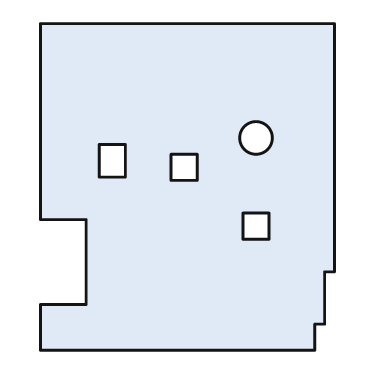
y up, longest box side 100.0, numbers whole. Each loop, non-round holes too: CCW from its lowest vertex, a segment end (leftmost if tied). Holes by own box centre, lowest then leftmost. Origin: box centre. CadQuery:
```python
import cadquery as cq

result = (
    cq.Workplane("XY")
    .moveTo(-45.0, -50.0)
    .lineTo(39.0, -50.0)
    .lineTo(39.0, -42.0)
    .lineTo(42.0, -42.0)
    .lineTo(42.0, -26.0)
    .lineTo(45.0, -26.0)
    .lineTo(45.0, 50.0)
    .lineTo(-45.0, 50.0)
    .lineTo(-45.0, -10.0)
    .lineTo(-31.0, -10.0)
    .lineTo(-31.0, -36.0)
    .lineTo(-45.0, -36.0)
    .close()
    .moveTo(17.0, -16.0)
    .lineTo(25.0, -16.0)
    .lineTo(25.0, -8.0)
    .lineTo(17.0, -8.0)
    .close()
    .moveTo(-5.0, 2.0)
    .lineTo(3.0, 2.0)
    .lineTo(3.0, 10.0)
    .lineTo(-5.0, 10.0)
    .close()
    .moveTo(-27.0, 3.0)
    .lineTo(-19.0, 3.0)
    .lineTo(-19.0, 13.0)
    .lineTo(-27.0, 13.0)
    .close()
    .moveTo(21.0, 15.0)
    .circle(5.0)
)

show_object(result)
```